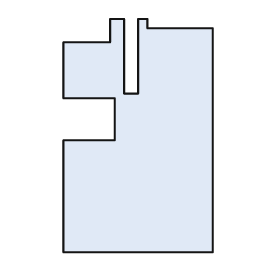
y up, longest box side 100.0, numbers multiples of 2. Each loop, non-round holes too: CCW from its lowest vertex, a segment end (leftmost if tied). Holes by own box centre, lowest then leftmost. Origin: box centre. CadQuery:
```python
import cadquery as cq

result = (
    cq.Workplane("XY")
    .moveTo(-32.0, -50.0)
    .lineTo(32.0, -50.0)
    .lineTo(32.0, 46.0)
    .lineTo(4.0, 46.0)
    .lineTo(4.0, 50.0)
    .lineTo(0.0, 50.0)
    .lineTo(0.0, 18.0)
    .lineTo(-6.0, 18.0)
    .lineTo(-6.0, 50.0)
    .lineTo(-12.0, 50.0)
    .lineTo(-12.0, 40.0)
    .lineTo(-32.0, 40.0)
    .lineTo(-32.0, 16.0)
    .lineTo(-10.0, 16.0)
    .lineTo(-10.0, -2.0)
    .lineTo(-32.0, -2.0)
    .close()
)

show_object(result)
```